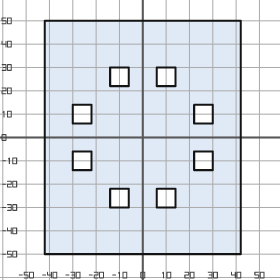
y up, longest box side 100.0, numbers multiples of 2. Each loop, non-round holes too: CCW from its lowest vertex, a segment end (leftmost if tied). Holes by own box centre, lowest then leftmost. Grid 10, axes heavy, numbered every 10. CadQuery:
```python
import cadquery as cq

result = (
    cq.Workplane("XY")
    .moveTo(-42.0, -50.0)
    .lineTo(42.0, -50.0)
    .lineTo(42.0, 50.0)
    .lineTo(-42.0, 50.0)
    .close()
    .moveTo(-14.0, -30.0)
    .lineTo(-6.0, -30.0)
    .lineTo(-6.0, -22.0)
    .lineTo(-14.0, -22.0)
    .close()
    .moveTo(6.0, -30.0)
    .lineTo(14.0, -30.0)
    .lineTo(14.0, -22.0)
    .lineTo(6.0, -22.0)
    .close()
    .moveTo(-30.0, -14.0)
    .lineTo(-22.0, -14.0)
    .lineTo(-22.0, -6.0)
    .lineTo(-30.0, -6.0)
    .close()
    .moveTo(22.0, -14.0)
    .lineTo(30.0, -14.0)
    .lineTo(30.0, -6.0)
    .lineTo(22.0, -6.0)
    .close()
    .moveTo(-30.0, 6.0)
    .lineTo(-22.0, 6.0)
    .lineTo(-22.0, 14.0)
    .lineTo(-30.0, 14.0)
    .close()
    .moveTo(22.0, 6.0)
    .lineTo(30.0, 6.0)
    .lineTo(30.0, 14.0)
    .lineTo(22.0, 14.0)
    .close()
    .moveTo(-14.0, 22.0)
    .lineTo(-6.0, 22.0)
    .lineTo(-6.0, 30.0)
    .lineTo(-14.0, 30.0)
    .close()
    .moveTo(6.0, 22.0)
    .lineTo(14.0, 22.0)
    .lineTo(14.0, 30.0)
    .lineTo(6.0, 30.0)
    .close()
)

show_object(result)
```